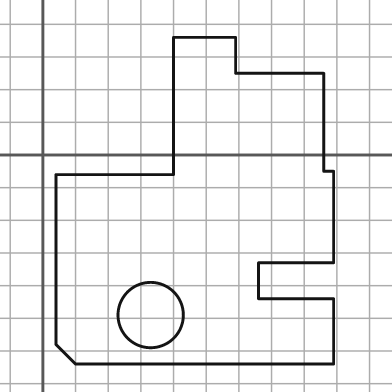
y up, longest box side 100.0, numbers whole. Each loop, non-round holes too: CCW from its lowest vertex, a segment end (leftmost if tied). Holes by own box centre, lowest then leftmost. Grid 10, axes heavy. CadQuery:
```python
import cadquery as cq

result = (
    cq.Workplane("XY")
    .moveTo(10.0, -64.0)
    .lineTo(89.0, -64.0)
    .lineTo(89.0, -44.0)
    .lineTo(66.0, -44.0)
    .lineTo(66.0, -33.0)
    .lineTo(89.0, -33.0)
    .lineTo(89.0, -5.0)
    .lineTo(86.0, -5.0)
    .lineTo(86.0, 25.0)
    .lineTo(59.0, 25.0)
    .lineTo(59.0, 36.0)
    .lineTo(40.0, 36.0)
    .lineTo(40.0, -6.0)
    .lineTo(4.0, -6.0)
    .lineTo(4.0, -58.0)
    .close()
    .moveTo(33.0, -49.0)
    .circle(10.0)
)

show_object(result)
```